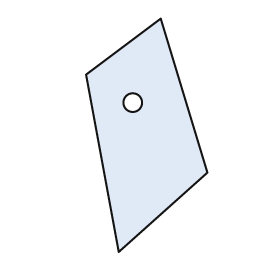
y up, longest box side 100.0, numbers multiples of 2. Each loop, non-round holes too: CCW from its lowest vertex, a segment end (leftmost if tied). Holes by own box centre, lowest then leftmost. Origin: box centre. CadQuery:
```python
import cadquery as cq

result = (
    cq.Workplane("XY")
    .moveTo(-12.0, -50.0)
    .lineTo(26.0, -16.0)
    .lineTo(6.0, 50.0)
    .lineTo(-26.0, 26.0)
    .close()
    .moveTo(-6.0, 14.0)
    .circle(4.0)
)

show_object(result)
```